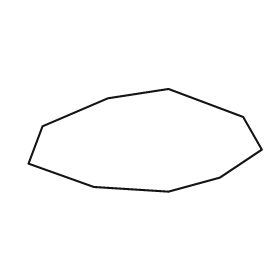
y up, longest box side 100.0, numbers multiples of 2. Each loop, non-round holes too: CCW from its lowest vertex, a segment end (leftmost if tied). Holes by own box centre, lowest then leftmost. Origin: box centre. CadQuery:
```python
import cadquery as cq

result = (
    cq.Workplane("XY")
    .moveTo(10.0, -22.0)
    .lineTo(32.0, -16.0)
    .lineTo(50.0, -4.0)
    .lineTo(42.0, 10.0)
    .lineTo(10.0, 22.0)
    .lineTo(-16.0, 18.0)
    .lineTo(-44.0, 6.0)
    .lineTo(-50.0, -10.0)
    .lineTo(-22.0, -20.0)
    .close()
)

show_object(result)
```